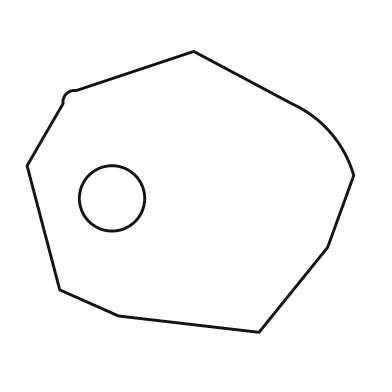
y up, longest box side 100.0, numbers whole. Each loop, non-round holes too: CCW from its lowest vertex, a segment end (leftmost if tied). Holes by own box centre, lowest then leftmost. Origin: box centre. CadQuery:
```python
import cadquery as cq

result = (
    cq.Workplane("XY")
    .moveTo(21.0, -43.0)
    .lineTo(42.0, -17.0)
    .lineTo(50.0, 5.0)
    .threePointArc((43.0, 18.0), (31.0, 27.0))
    .lineTo(1.0, 43.0)
    .lineTo(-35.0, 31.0)
    .threePointArc((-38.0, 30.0), (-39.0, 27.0))
    .lineTo(-50.0, 8.0)
    .lineTo(-40.0, -30.0)
    .lineTo(-22.0, -38.0)
    .close()
    .moveTo(-24.0, -2.0)
    .circle(10.0)
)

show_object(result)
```